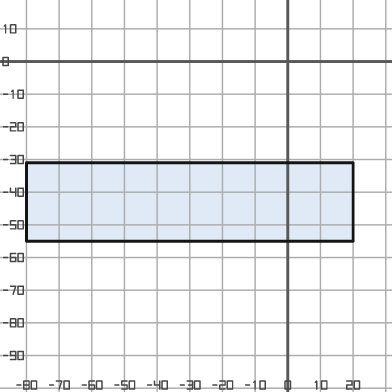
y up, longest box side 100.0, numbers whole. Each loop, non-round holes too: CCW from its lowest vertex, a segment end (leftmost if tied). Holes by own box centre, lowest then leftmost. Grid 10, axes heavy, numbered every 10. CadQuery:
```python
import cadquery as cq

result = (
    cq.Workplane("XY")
    .moveTo(-80.0, -55.0)
    .lineTo(20.0, -55.0)
    .lineTo(20.0, -31.0)
    .lineTo(-80.0, -31.0)
    .close()
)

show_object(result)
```